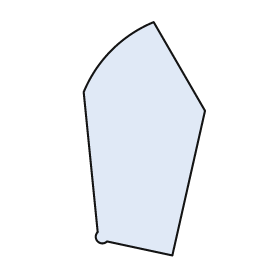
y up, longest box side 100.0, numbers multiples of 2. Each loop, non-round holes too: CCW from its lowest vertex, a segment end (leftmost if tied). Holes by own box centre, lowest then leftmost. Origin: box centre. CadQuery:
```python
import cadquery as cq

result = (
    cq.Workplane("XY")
    .moveTo(12.0, -50.0)
    .lineTo(26.0, 12.0)
    .lineTo(4.0, 50.0)
    .threePointArc((-14.0, 38.0), (-26.0, 20.0))
    .lineTo(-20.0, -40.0)
    .threePointArc((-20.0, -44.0), (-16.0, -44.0))
    .close()
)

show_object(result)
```